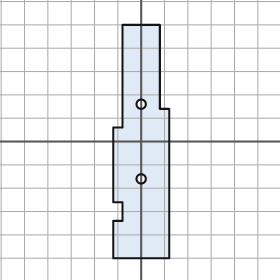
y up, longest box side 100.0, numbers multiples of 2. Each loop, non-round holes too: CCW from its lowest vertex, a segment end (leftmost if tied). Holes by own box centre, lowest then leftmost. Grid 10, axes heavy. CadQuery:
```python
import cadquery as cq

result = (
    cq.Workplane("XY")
    .moveTo(-12.0, -50.0)
    .lineTo(12.0, -50.0)
    .lineTo(12.0, 14.0)
    .lineTo(8.0, 14.0)
    .lineTo(8.0, 50.0)
    .lineTo(-8.0, 50.0)
    .lineTo(-8.0, 6.0)
    .lineTo(-12.0, 6.0)
    .lineTo(-12.0, -26.0)
    .lineTo(-8.0, -26.0)
    .lineTo(-8.0, -34.0)
    .lineTo(-12.0, -34.0)
    .close()
    .moveTo(0.0, -16.0)
    .circle(2.0)
    .moveTo(0.0, 16.0)
    .circle(2.0)
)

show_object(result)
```